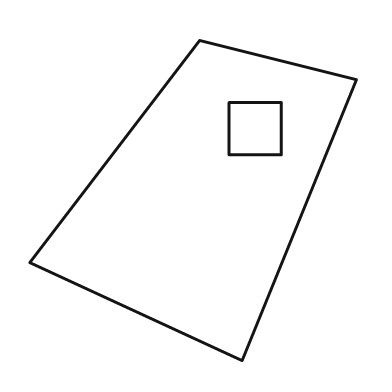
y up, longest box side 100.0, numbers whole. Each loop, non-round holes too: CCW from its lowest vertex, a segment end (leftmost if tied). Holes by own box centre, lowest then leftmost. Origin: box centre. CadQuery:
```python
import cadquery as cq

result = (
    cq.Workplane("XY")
    .moveTo(15.0, -49.0)
    .lineTo(50.0, 37.0)
    .lineTo(2.0, 49.0)
    .lineTo(-50.0, -19.0)
    .close()
    .moveTo(11.0, 14.0)
    .lineTo(27.0, 14.0)
    .lineTo(27.0, 30.0)
    .lineTo(11.0, 30.0)
    .close()
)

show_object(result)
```